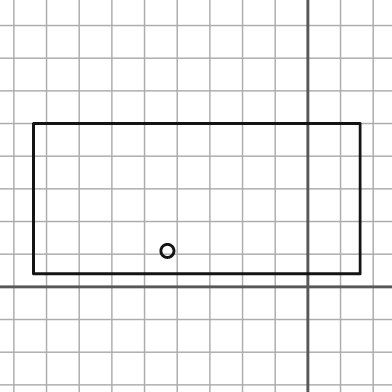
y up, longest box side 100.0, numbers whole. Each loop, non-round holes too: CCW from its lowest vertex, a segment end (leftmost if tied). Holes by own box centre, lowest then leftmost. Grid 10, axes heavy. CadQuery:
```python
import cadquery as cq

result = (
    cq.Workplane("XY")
    .moveTo(-84.0, 4.0)
    .lineTo(16.0, 4.0)
    .lineTo(16.0, 50.0)
    .lineTo(-84.0, 50.0)
    .close()
    .moveTo(-43.0, 11.0)
    .circle(2.0)
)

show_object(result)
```